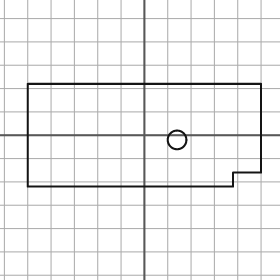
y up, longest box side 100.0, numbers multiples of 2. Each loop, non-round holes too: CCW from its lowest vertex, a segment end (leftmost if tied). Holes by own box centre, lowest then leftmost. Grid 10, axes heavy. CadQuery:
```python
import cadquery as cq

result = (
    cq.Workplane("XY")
    .moveTo(-50.0, -22.0)
    .lineTo(38.0, -22.0)
    .lineTo(38.0, -16.0)
    .lineTo(50.0, -16.0)
    .lineTo(50.0, 22.0)
    .lineTo(-50.0, 22.0)
    .close()
    .moveTo(14.0, -2.0)
    .circle(4.0)
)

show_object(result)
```